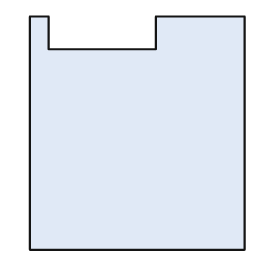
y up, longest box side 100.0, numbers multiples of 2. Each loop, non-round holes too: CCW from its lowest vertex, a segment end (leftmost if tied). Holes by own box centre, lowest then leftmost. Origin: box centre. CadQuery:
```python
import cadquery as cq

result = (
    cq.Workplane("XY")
    .moveTo(-46.0, -50.0)
    .lineTo(46.0, -50.0)
    .lineTo(46.0, 50.0)
    .lineTo(8.0, 50.0)
    .lineTo(8.0, 36.0)
    .lineTo(-38.0, 36.0)
    .lineTo(-38.0, 50.0)
    .lineTo(-46.0, 50.0)
    .close()
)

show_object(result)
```